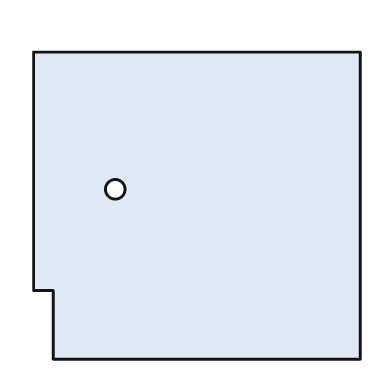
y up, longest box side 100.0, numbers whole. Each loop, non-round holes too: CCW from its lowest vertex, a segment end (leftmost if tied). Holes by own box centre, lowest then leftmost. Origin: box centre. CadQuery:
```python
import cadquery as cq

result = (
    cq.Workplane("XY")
    .moveTo(-44.0, -47.0)
    .lineTo(50.0, -47.0)
    .lineTo(50.0, 47.0)
    .lineTo(-50.0, 47.0)
    .lineTo(-50.0, -26.0)
    .lineTo(-44.0, -26.0)
    .close()
    .moveTo(-25.0, 5.0)
    .circle(3.0)
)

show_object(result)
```